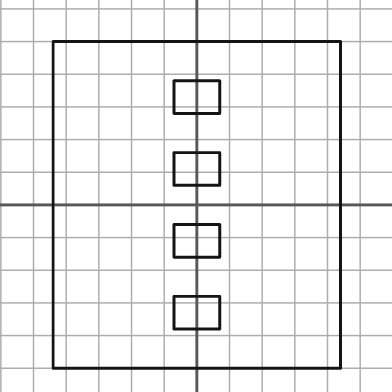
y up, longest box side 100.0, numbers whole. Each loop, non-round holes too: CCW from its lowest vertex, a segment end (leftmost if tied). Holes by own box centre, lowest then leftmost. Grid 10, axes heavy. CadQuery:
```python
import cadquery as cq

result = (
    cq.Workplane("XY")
    .moveTo(-44.0, -50.0)
    .lineTo(44.0, -50.0)
    .lineTo(44.0, 50.0)
    .lineTo(-44.0, 50.0)
    .close()
    .moveTo(-7.0, -38.0)
    .lineTo(7.0, -38.0)
    .lineTo(7.0, -28.0)
    .lineTo(-7.0, -28.0)
    .close()
    .moveTo(-7.0, -16.0)
    .lineTo(7.0, -16.0)
    .lineTo(7.0, -6.0)
    .lineTo(-7.0, -6.0)
    .close()
    .moveTo(-7.0, 6.0)
    .lineTo(7.0, 6.0)
    .lineTo(7.0, 16.0)
    .lineTo(-7.0, 16.0)
    .close()
    .moveTo(-7.0, 28.0)
    .lineTo(7.0, 28.0)
    .lineTo(7.0, 38.0)
    .lineTo(-7.0, 38.0)
    .close()
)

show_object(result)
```